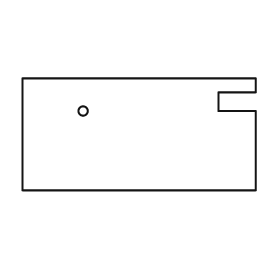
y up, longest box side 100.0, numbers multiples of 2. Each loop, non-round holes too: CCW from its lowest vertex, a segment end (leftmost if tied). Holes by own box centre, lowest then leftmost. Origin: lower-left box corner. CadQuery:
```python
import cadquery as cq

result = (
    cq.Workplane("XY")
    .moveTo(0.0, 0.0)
    .lineTo(100.0, 0.0)
    .lineTo(100.0, 34.0)
    .lineTo(84.0, 34.0)
    .lineTo(84.0, 42.0)
    .lineTo(100.0, 42.0)
    .lineTo(100.0, 48.0)
    .lineTo(0.0, 48.0)
    .close()
    .moveTo(26.0, 34.0)
    .circle(2.0)
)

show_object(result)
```